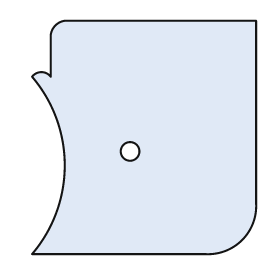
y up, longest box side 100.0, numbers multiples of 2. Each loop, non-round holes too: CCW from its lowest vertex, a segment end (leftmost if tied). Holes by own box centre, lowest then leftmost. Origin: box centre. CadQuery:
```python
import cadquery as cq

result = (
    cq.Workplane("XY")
    .moveTo(-48.0, -50.0)
    .lineTo(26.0, -50.0)
    .threePointArc((42.0, -44.0), (48.0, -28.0))
    .lineTo(48.0, 50.0)
    .lineTo(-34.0, 50.0)
    .threePointArc((-38.0, 48.0), (-40.0, 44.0))
    .lineTo(-40.0, 26.0)
    .threePointArc((-44.0, 28.0), (-48.0, 26.0))
    .threePointArc((-34.0, -12.0), (-48.0, -50.0))
    .close()
    .moveTo(-6.0, -6.0)
    .circle(4.0)
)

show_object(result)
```